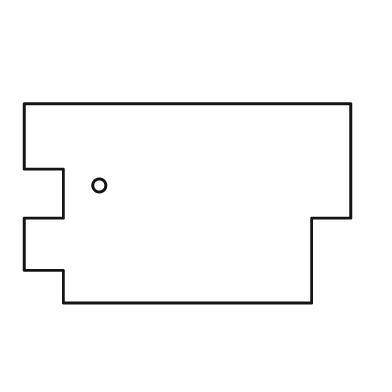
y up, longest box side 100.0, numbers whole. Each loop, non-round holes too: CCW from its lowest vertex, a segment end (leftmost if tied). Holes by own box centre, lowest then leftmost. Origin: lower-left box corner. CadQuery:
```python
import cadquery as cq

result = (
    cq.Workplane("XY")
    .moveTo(12.0, 0.0)
    .lineTo(88.0, 0.0)
    .lineTo(88.0, 26.0)
    .lineTo(100.0, 26.0)
    .lineTo(100.0, 61.0)
    .lineTo(0.0, 61.0)
    .lineTo(0.0, 41.0)
    .lineTo(12.0, 41.0)
    .lineTo(12.0, 26.0)
    .lineTo(0.0, 26.0)
    .lineTo(0.0, 10.0)
    .lineTo(12.0, 10.0)
    .close()
    .moveTo(23.0, 36.0)
    .circle(2.0)
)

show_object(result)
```